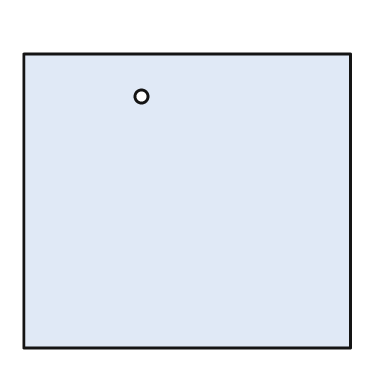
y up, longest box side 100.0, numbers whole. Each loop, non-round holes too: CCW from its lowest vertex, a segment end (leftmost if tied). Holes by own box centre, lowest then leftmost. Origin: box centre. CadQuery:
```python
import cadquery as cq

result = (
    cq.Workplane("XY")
    .moveTo(-50.0, -45.0)
    .lineTo(50.0, -45.0)
    .lineTo(50.0, 45.0)
    .lineTo(-50.0, 45.0)
    .close()
    .moveTo(-14.0, 32.0)
    .circle(2.0)
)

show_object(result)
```